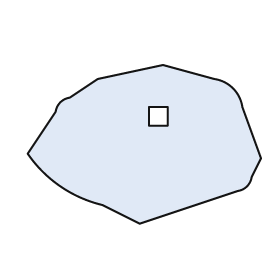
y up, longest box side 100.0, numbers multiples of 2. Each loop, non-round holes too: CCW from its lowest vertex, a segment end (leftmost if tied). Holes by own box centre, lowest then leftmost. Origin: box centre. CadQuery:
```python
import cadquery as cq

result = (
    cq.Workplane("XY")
    .moveTo(-2.0, -34.0)
    .lineTo(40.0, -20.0)
    .threePointArc((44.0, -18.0), (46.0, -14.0))
    .lineTo(50.0, -6.0)
    .lineTo(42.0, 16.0)
    .threePointArc((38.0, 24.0), (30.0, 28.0))
    .lineTo(8.0, 34.0)
    .lineTo(-20.0, 28.0)
    .lineTo(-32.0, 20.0)
    .threePointArc((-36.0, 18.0), (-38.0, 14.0))
    .lineTo(-50.0, -4.0)
    .threePointArc((-36.0, -18.0), (-18.0, -26.0))
    .close()
    .moveTo(2.0, 8.0)
    .lineTo(10.0, 8.0)
    .lineTo(10.0, 16.0)
    .lineTo(2.0, 16.0)
    .close()
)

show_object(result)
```